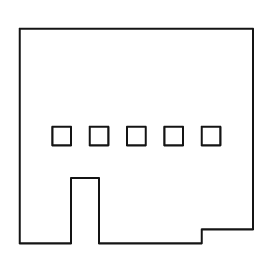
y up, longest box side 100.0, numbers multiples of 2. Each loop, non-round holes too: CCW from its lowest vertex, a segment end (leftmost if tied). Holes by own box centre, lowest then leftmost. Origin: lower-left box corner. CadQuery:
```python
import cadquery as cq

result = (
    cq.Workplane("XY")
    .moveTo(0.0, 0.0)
    .lineTo(22.0, 0.0)
    .lineTo(22.0, 28.0)
    .lineTo(34.0, 28.0)
    .lineTo(34.0, 0.0)
    .lineTo(78.0, 0.0)
    .lineTo(78.0, 6.0)
    .lineTo(100.0, 6.0)
    .lineTo(100.0, 92.0)
    .lineTo(0.0, 92.0)
    .close()
    .moveTo(14.0, 42.0)
    .lineTo(22.0, 42.0)
    .lineTo(22.0, 50.0)
    .lineTo(14.0, 50.0)
    .close()
    .moveTo(30.0, 42.0)
    .lineTo(38.0, 42.0)
    .lineTo(38.0, 50.0)
    .lineTo(30.0, 50.0)
    .close()
    .moveTo(46.0, 42.0)
    .lineTo(54.0, 42.0)
    .lineTo(54.0, 50.0)
    .lineTo(46.0, 50.0)
    .close()
    .moveTo(62.0, 42.0)
    .lineTo(70.0, 42.0)
    .lineTo(70.0, 50.0)
    .lineTo(62.0, 50.0)
    .close()
    .moveTo(78.0, 42.0)
    .lineTo(86.0, 42.0)
    .lineTo(86.0, 50.0)
    .lineTo(78.0, 50.0)
    .close()
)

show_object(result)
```